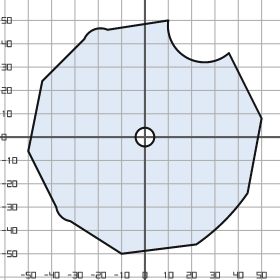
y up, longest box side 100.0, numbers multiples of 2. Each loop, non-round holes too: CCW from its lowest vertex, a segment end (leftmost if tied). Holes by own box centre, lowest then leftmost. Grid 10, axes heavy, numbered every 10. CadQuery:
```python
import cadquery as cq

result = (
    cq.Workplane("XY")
    .moveTo(-10.0, -50.0)
    .lineTo(22.0, -46.0)
    .threePointArc((34.0, -36.0), (44.0, -24.0))
    .lineTo(50.0, 8.0)
    .lineTo(36.0, 36.0)
    .threePointArc((18.0, 34.0), (10.0, 50.0))
    .lineTo(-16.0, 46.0)
    .threePointArc((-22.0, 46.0), (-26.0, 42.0))
    .lineTo(-44.0, 24.0)
    .lineTo(-50.0, -6.0)
    .lineTo(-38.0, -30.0)
    .threePointArc((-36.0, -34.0), (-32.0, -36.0))
    .close()
    .moveTo(0.0, 0.0)
    .circle(4.0)
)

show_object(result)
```